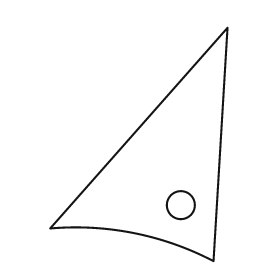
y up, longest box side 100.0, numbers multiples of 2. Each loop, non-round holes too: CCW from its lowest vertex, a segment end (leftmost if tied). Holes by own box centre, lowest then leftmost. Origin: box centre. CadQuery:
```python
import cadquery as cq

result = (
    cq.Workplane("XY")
    .moveTo(32.0, -50.0)
    .lineTo(38.0, 50.0)
    .lineTo(-38.0, -36.0)
    .threePointArc((-2.0, -38.0), (32.0, -50.0))
    .close()
    .moveTo(18.0, -26.0)
    .circle(6.0)
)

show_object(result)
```